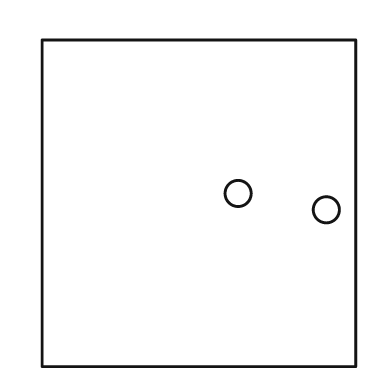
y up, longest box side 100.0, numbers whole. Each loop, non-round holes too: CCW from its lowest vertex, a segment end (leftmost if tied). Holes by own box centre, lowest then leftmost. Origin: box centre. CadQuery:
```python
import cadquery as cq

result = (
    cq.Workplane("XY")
    .moveTo(-48.0, -50.0)
    .lineTo(48.0, -50.0)
    .lineTo(48.0, 50.0)
    .lineTo(-48.0, 50.0)
    .close()
    .moveTo(39.0, -2.0)
    .circle(4.0)
    .moveTo(12.0, 3.0)
    .circle(4.0)
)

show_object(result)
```